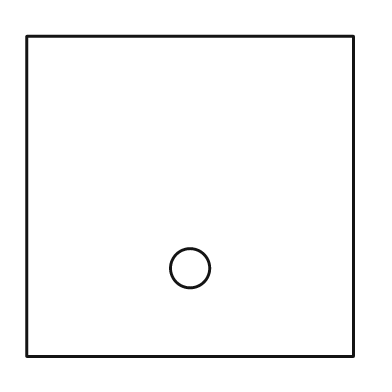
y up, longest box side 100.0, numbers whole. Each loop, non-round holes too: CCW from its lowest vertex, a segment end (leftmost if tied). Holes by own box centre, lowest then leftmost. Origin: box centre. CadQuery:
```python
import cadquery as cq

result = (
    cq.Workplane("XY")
    .moveTo(-50.0, -49.0)
    .lineTo(50.0, -49.0)
    .lineTo(50.0, 49.0)
    .lineTo(-50.0, 49.0)
    .close()
    .moveTo(0.0, -22.0)
    .circle(6.0)
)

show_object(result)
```